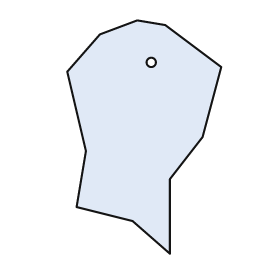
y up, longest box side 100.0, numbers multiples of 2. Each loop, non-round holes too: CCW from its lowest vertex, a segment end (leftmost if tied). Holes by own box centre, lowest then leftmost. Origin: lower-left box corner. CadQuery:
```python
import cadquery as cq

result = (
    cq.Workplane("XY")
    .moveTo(44.0, 0.0)
    .lineTo(44.0, 32.0)
    .lineTo(58.0, 50.0)
    .lineTo(66.0, 80.0)
    .lineTo(42.0, 98.0)
    .lineTo(30.0, 100.0)
    .lineTo(14.0, 94.0)
    .lineTo(0.0, 78.0)
    .lineTo(8.0, 44.0)
    .lineTo(4.0, 20.0)
    .lineTo(28.0, 14.0)
    .close()
    .moveTo(36.0, 82.0)
    .circle(2.0)
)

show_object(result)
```